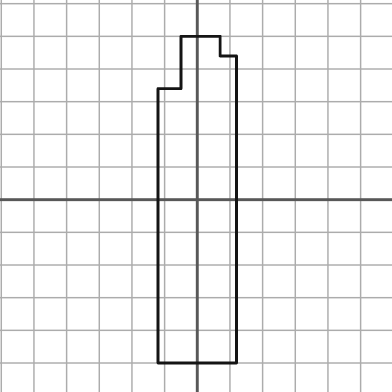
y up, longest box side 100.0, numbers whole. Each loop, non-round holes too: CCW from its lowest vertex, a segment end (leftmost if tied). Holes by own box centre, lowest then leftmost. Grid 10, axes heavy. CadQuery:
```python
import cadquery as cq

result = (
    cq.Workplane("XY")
    .moveTo(-12.0, -50.0)
    .lineTo(12.0, -50.0)
    .lineTo(12.0, 44.0)
    .lineTo(7.0, 44.0)
    .lineTo(7.0, 50.0)
    .lineTo(-5.0, 50.0)
    .lineTo(-5.0, 34.0)
    .lineTo(-12.0, 34.0)
    .close()
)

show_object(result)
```